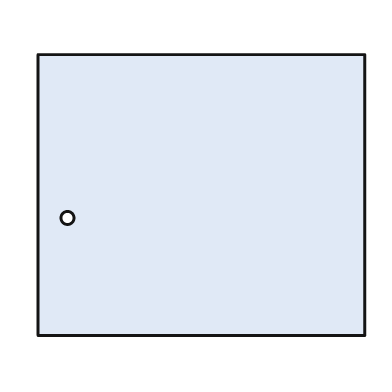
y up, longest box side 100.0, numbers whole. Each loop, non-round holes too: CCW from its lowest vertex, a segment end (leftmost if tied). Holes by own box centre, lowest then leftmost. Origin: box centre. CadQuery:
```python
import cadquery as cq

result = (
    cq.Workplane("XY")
    .moveTo(-50.0, -43.0)
    .lineTo(50.0, -43.0)
    .lineTo(50.0, 43.0)
    .lineTo(-50.0, 43.0)
    .close()
    .moveTo(-41.0, -7.0)
    .circle(2.0)
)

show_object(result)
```